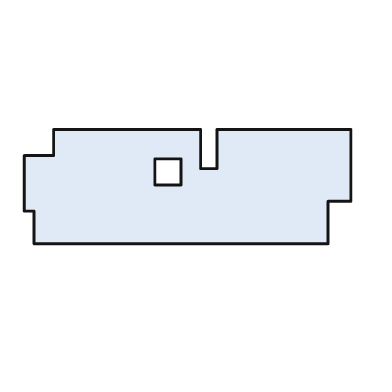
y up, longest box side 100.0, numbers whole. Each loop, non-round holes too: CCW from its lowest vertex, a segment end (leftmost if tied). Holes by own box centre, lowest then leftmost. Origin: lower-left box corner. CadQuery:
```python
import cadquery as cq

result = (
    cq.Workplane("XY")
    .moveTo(3.0, 0.0)
    .lineTo(93.0, 0.0)
    .lineTo(93.0, 13.0)
    .lineTo(100.0, 13.0)
    .lineTo(100.0, 35.0)
    .lineTo(59.0, 35.0)
    .lineTo(59.0, 23.0)
    .lineTo(54.0, 23.0)
    .lineTo(54.0, 35.0)
    .lineTo(9.0, 35.0)
    .lineTo(9.0, 27.0)
    .lineTo(0.0, 27.0)
    .lineTo(0.0, 10.0)
    .lineTo(3.0, 10.0)
    .close()
    .moveTo(40.0, 18.0)
    .lineTo(48.0, 18.0)
    .lineTo(48.0, 26.0)
    .lineTo(40.0, 26.0)
    .close()
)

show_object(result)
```